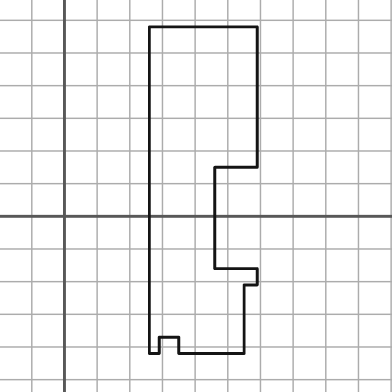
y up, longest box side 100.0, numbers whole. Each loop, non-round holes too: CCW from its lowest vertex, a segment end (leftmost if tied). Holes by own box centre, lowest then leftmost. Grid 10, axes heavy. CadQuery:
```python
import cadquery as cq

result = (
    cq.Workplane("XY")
    .moveTo(26.0, -42.0)
    .lineTo(29.0, -42.0)
    .lineTo(29.0, -37.0)
    .lineTo(35.0, -37.0)
    .lineTo(35.0, -42.0)
    .lineTo(55.0, -42.0)
    .lineTo(55.0, -21.0)
    .lineTo(59.0, -21.0)
    .lineTo(59.0, -16.0)
    .lineTo(46.0, -16.0)
    .lineTo(46.0, 15.0)
    .lineTo(59.0, 15.0)
    .lineTo(59.0, 58.0)
    .lineTo(26.0, 58.0)
    .close()
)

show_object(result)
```